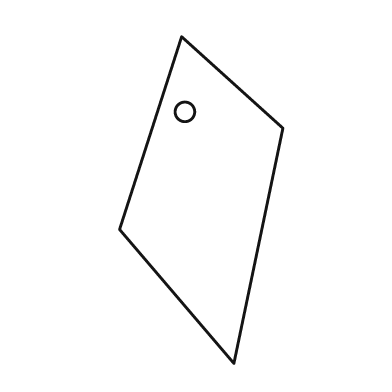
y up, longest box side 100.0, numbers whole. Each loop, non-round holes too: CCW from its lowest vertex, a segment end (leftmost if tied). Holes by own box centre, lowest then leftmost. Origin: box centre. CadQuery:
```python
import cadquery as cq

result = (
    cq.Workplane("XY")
    .moveTo(10.0, -50.0)
    .lineTo(25.0, 22.0)
    .lineTo(-6.0, 50.0)
    .lineTo(-25.0, -9.0)
    .close()
    .moveTo(-5.0, 27.0)
    .circle(3.0)
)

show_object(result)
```